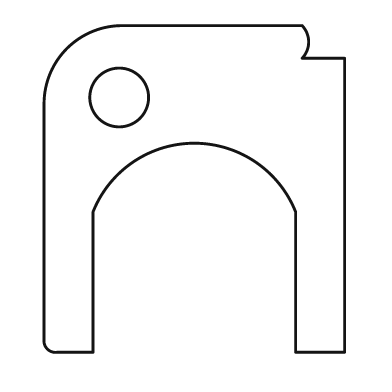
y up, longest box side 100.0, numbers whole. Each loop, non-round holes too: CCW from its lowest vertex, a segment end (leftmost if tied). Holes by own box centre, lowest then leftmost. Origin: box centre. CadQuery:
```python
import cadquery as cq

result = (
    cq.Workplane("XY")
    .moveTo(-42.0, -50.0)
    .lineTo(-31.0, -50.0)
    .lineTo(-31.0, -7.0)
    .threePointArc((0.0, 14.0), (31.0, -7.0))
    .lineTo(31.0, -50.0)
    .lineTo(46.0, -50.0)
    .lineTo(46.0, 40.0)
    .lineTo(33.0, 40.0)
    .threePointArc((35.0, 45.0), (33.0, 50.0))
    .lineTo(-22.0, 50.0)
    .threePointArc((-39.0, 43.0), (-46.0, 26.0))
    .lineTo(-46.0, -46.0)
    .threePointArc((-45.0, -49.0), (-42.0, -50.0))
    .close()
    .moveTo(-23.0, 28.0)
    .circle(9.0)
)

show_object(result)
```